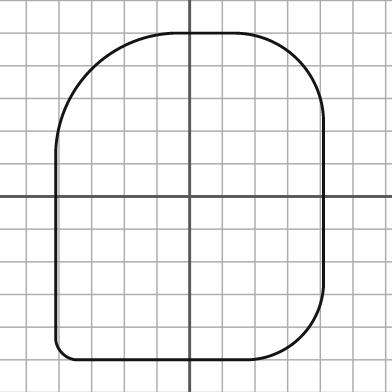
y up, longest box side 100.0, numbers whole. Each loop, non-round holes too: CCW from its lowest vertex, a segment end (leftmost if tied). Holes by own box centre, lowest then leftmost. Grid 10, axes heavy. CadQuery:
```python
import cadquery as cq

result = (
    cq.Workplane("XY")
    .moveTo(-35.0, -50.0)
    .lineTo(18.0, -50.0)
    .threePointArc((34.0, -43.0), (41.0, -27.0))
    .lineTo(41.0, 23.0)
    .threePointArc((33.0, 42.0), (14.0, 50.0))
    .lineTo(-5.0, 50.0)
    .threePointArc((-30.0, 39.0), (-41.0, 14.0))
    .lineTo(-41.0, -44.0)
    .threePointArc((-39.0, -48.0), (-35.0, -50.0))
    .close()
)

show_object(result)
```